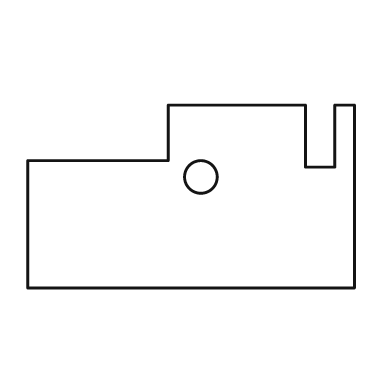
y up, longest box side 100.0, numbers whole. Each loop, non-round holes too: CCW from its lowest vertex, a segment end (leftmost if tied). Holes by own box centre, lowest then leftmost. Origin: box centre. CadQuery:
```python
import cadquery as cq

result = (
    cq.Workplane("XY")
    .moveTo(-50.0, -28.0)
    .lineTo(50.0, -28.0)
    .lineTo(50.0, 28.0)
    .lineTo(44.0, 28.0)
    .lineTo(44.0, 9.0)
    .lineTo(35.0, 9.0)
    .lineTo(35.0, 28.0)
    .lineTo(-7.0, 28.0)
    .lineTo(-7.0, 11.0)
    .lineTo(-50.0, 11.0)
    .close()
    .moveTo(3.0, 6.0)
    .circle(5.0)
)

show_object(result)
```